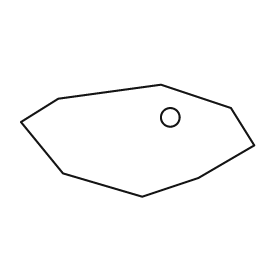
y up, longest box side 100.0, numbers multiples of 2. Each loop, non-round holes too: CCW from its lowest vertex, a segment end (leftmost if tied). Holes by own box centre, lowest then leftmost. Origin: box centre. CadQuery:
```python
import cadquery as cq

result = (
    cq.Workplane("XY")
    .moveTo(2.0, -24.0)
    .lineTo(26.0, -16.0)
    .lineTo(50.0, -2.0)
    .lineTo(40.0, 14.0)
    .lineTo(10.0, 24.0)
    .lineTo(-34.0, 18.0)
    .lineTo(-50.0, 8.0)
    .lineTo(-32.0, -14.0)
    .close()
    .moveTo(14.0, 10.0)
    .circle(4.0)
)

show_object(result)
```